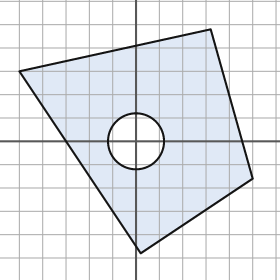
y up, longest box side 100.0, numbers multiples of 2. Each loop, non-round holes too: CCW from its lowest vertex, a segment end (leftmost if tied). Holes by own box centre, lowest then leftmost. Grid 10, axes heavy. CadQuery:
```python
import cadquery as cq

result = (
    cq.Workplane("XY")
    .moveTo(2.0, -48.0)
    .lineTo(50.0, -16.0)
    .lineTo(32.0, 48.0)
    .lineTo(-50.0, 30.0)
    .close()
    .moveTo(0.0, 0.0)
    .circle(12.0)
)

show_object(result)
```